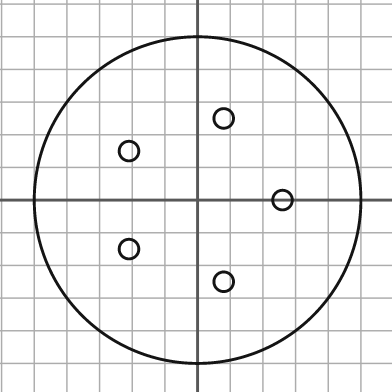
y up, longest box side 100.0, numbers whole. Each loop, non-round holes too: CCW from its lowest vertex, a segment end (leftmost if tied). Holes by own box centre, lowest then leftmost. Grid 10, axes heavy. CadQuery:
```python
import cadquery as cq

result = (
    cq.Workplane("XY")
    .moveTo(0.0, 0.0)
    .circle(50.0)
    .moveTo(8.0, -25.0)
    .circle(3.0)
    .moveTo(-21.0, -15.0)
    .circle(3.0)
    .moveTo(26.0, 0.0)
    .circle(3.0)
    .moveTo(-21.0, 15.0)
    .circle(3.0)
    .moveTo(8.0, 25.0)
    .circle(3.0)
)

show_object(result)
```